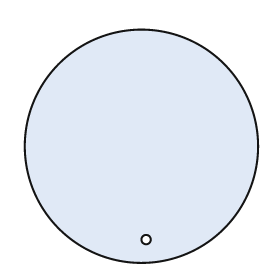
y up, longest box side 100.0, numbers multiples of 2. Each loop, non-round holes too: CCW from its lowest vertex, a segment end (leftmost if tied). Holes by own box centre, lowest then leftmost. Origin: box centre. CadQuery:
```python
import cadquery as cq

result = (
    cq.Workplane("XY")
    .moveTo(0.0, 0.0)
    .circle(50.0)
    .moveTo(2.0, -40.0)
    .circle(2.0)
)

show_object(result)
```